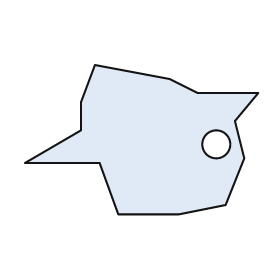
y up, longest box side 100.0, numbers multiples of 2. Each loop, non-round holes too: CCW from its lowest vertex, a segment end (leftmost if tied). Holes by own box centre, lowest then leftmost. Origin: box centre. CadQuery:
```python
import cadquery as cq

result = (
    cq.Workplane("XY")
    .moveTo(-10.0, -32.0)
    .lineTo(16.0, -32.0)
    .lineTo(36.0, -28.0)
    .lineTo(44.0, -8.0)
    .lineTo(40.0, 8.0)
    .lineTo(50.0, 20.0)
    .lineTo(24.0, 20.0)
    .lineTo(12.0, 26.0)
    .lineTo(-20.0, 32.0)
    .lineTo(-26.0, 16.0)
    .lineTo(-26.0, 4.0)
    .lineTo(-50.0, -10.0)
    .lineTo(-18.0, -10.0)
    .close()
    .moveTo(32.0, -2.0)
    .circle(6.0)
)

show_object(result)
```